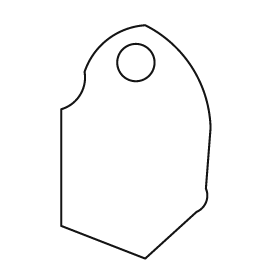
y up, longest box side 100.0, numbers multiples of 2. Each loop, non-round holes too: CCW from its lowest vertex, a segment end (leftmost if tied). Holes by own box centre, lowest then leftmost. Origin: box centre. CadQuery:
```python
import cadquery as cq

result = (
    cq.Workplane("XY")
    .moveTo(4.0, -50.0)
    .lineTo(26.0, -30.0)
    .threePointArc((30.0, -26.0), (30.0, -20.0))
    .lineTo(32.0, 6.0)
    .threePointArc((24.0, 32.0), (4.0, 50.0))
    .threePointArc((-12.0, 44.0), (-22.0, 30.0))
    .threePointArc((-24.0, 20.0), (-32.0, 14.0))
    .lineTo(-32.0, -36.0)
    .close()
    .moveTo(0.0, 34.0)
    .circle(8.0)
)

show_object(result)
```